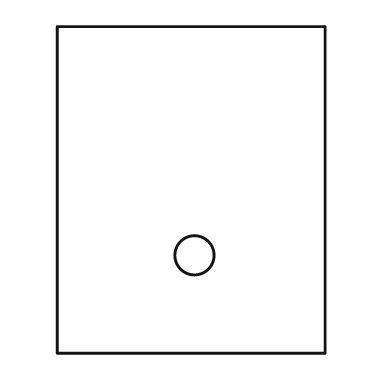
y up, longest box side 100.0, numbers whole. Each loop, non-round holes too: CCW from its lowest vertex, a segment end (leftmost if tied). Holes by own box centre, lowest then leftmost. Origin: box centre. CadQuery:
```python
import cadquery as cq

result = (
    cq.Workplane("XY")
    .moveTo(-41.0, -50.0)
    .lineTo(41.0, -50.0)
    .lineTo(41.0, 50.0)
    .lineTo(-41.0, 50.0)
    .close()
    .moveTo(1.0, -20.0)
    .circle(6.0)
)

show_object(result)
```